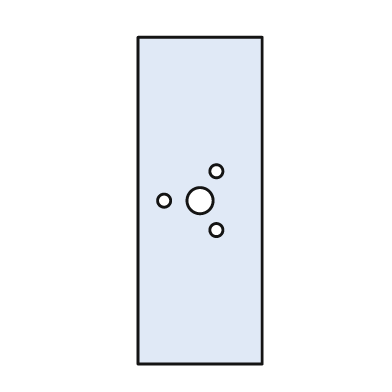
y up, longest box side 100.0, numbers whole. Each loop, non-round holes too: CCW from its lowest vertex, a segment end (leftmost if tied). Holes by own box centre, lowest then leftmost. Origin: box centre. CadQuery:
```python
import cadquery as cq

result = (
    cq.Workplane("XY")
    .moveTo(-19.0, -50.0)
    .lineTo(19.0, -50.0)
    .lineTo(19.0, 50.0)
    .lineTo(-19.0, 50.0)
    .close()
    .moveTo(5.0, -9.0)
    .circle(2.0)
    .moveTo(-11.0, 0.0)
    .circle(2.0)
    .moveTo(0.0, 0.0)
    .circle(4.0)
    .moveTo(5.0, 9.0)
    .circle(2.0)
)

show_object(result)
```